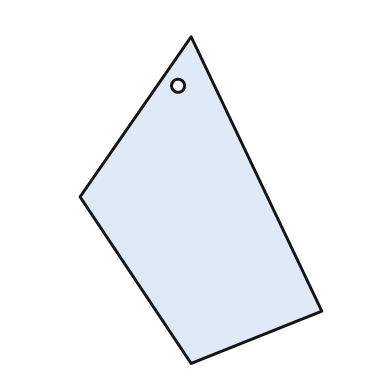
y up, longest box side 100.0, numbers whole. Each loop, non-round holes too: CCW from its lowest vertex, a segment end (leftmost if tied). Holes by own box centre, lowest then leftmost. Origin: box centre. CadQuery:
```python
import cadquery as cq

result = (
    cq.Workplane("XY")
    .moveTo(-3.0, -50.0)
    .lineTo(37.0, -34.0)
    .lineTo(-3.0, 50.0)
    .lineTo(-37.0, 1.0)
    .close()
    .moveTo(-7.0, 35.0)
    .circle(2.0)
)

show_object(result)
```